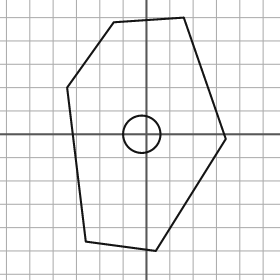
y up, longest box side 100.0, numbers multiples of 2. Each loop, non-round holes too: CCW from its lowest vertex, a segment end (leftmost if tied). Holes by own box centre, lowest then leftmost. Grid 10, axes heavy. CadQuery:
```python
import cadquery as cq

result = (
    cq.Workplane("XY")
    .moveTo(4.0, -50.0)
    .lineTo(34.0, -2.0)
    .lineTo(16.0, 50.0)
    .lineTo(-14.0, 48.0)
    .lineTo(-34.0, 20.0)
    .lineTo(-26.0, -46.0)
    .close()
    .moveTo(-2.0, 0.0)
    .circle(8.0)
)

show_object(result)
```